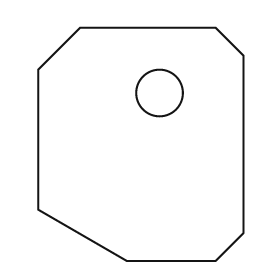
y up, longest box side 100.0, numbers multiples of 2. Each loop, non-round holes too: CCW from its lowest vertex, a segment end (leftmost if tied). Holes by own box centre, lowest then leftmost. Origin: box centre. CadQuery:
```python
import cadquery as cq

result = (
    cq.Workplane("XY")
    .moveTo(-6.0, -50.0)
    .lineTo(32.0, -50.0)
    .lineTo(44.0, -38.0)
    .lineTo(44.0, 38.0)
    .lineTo(32.0, 50.0)
    .lineTo(-26.0, 50.0)
    .lineTo(-44.0, 32.0)
    .lineTo(-44.0, -28.0)
    .close()
    .moveTo(8.0, 22.0)
    .circle(10.0)
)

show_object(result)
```